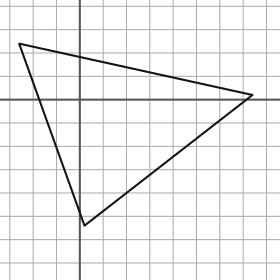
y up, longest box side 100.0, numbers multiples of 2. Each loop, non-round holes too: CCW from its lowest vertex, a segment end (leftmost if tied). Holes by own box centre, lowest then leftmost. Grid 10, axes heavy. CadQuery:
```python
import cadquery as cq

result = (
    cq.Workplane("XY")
    .moveTo(2.0, -54.0)
    .lineTo(74.0, 2.0)
    .lineTo(-26.0, 24.0)
    .close()
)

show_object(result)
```